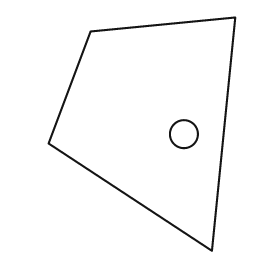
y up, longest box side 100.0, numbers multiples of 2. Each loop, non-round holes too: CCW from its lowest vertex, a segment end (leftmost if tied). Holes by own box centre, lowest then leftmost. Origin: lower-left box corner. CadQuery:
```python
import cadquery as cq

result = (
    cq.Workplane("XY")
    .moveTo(70.0, 0.0)
    .lineTo(80.0, 100.0)
    .lineTo(18.0, 94.0)
    .lineTo(0.0, 46.0)
    .close()
    .moveTo(58.0, 50.0)
    .circle(6.0)
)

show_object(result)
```